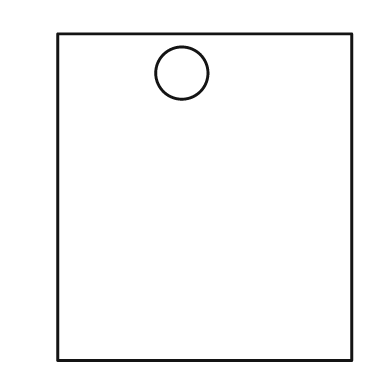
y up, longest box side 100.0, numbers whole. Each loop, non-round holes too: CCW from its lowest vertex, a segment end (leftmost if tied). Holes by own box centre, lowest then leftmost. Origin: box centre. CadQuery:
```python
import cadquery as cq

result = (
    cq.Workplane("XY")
    .moveTo(-45.0, -50.0)
    .lineTo(45.0, -50.0)
    .lineTo(45.0, 50.0)
    .lineTo(-45.0, 50.0)
    .close()
    .moveTo(-7.0, 38.0)
    .circle(8.0)
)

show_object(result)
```